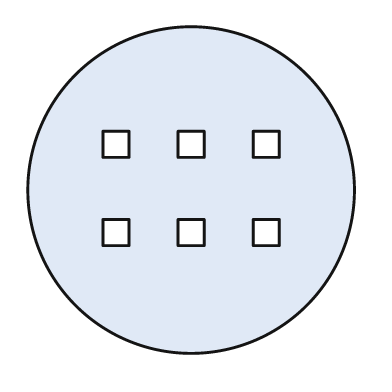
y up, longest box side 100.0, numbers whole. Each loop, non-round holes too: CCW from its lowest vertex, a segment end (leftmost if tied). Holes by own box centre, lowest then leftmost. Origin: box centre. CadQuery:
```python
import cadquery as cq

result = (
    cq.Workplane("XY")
    .moveTo(0.0, 0.0)
    .circle(50.0)
    .moveTo(-27.0, -17.0)
    .lineTo(-19.0, -17.0)
    .lineTo(-19.0, -9.0)
    .lineTo(-27.0, -9.0)
    .close()
    .moveTo(-4.0, -17.0)
    .lineTo(4.0, -17.0)
    .lineTo(4.0, -9.0)
    .lineTo(-4.0, -9.0)
    .close()
    .moveTo(19.0, -17.0)
    .lineTo(27.0, -17.0)
    .lineTo(27.0, -9.0)
    .lineTo(19.0, -9.0)
    .close()
    .moveTo(-27.0, 10.0)
    .lineTo(-19.0, 10.0)
    .lineTo(-19.0, 18.0)
    .lineTo(-27.0, 18.0)
    .close()
    .moveTo(-4.0, 10.0)
    .lineTo(4.0, 10.0)
    .lineTo(4.0, 18.0)
    .lineTo(-4.0, 18.0)
    .close()
    .moveTo(19.0, 10.0)
    .lineTo(27.0, 10.0)
    .lineTo(27.0, 18.0)
    .lineTo(19.0, 18.0)
    .close()
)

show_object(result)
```